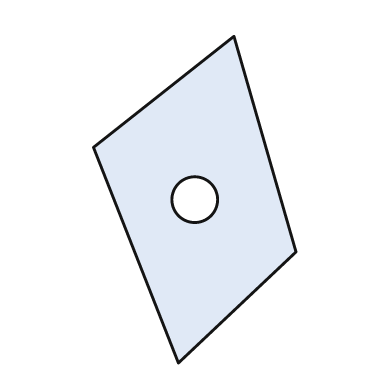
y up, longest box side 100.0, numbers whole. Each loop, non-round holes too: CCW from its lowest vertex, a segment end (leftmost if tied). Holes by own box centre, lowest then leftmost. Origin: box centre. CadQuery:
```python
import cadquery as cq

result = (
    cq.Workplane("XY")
    .moveTo(-5.0, -50.0)
    .lineTo(31.0, -16.0)
    .lineTo(12.0, 50.0)
    .lineTo(-31.0, 16.0)
    .close()
    .moveTo(0.0, 0.0)
    .circle(7.0)
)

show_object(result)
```